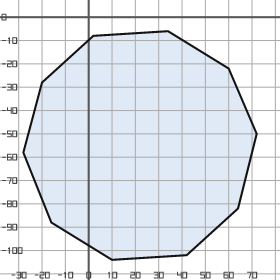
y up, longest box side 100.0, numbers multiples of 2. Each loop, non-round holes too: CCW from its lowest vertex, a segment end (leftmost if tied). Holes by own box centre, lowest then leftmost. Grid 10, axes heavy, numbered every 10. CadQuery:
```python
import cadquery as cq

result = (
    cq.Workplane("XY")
    .moveTo(10.0, -104.0)
    .lineTo(42.0, -102.0)
    .lineTo(64.0, -82.0)
    .lineTo(72.0, -50.0)
    .lineTo(60.0, -22.0)
    .lineTo(34.0, -6.0)
    .lineTo(2.0, -8.0)
    .lineTo(-20.0, -28.0)
    .lineTo(-28.0, -58.0)
    .lineTo(-16.0, -88.0)
    .close()
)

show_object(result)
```